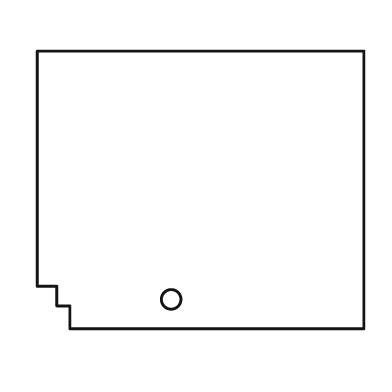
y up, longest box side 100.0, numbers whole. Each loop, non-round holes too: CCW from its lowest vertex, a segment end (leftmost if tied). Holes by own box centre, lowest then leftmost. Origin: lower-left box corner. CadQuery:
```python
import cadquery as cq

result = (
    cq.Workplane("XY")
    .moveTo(10.0, 0.0)
    .lineTo(100.0, 0.0)
    .lineTo(100.0, 85.0)
    .lineTo(0.0, 85.0)
    .lineTo(0.0, 13.0)
    .lineTo(6.0, 13.0)
    .lineTo(6.0, 7.0)
    .lineTo(10.0, 7.0)
    .close()
    .moveTo(41.0, 9.0)
    .circle(3.0)
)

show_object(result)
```